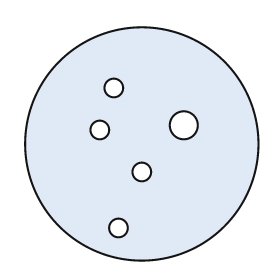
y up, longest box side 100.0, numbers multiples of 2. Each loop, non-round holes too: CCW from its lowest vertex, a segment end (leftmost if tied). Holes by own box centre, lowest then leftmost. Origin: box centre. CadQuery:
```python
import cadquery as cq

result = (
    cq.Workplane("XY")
    .moveTo(0.0, 0.0)
    .circle(50.0)
    .moveTo(-10.0, -36.0)
    .circle(4.0)
    .moveTo(0.0, -12.0)
    .circle(4.0)
    .moveTo(-18.0, 6.0)
    .circle(4.0)
    .moveTo(18.0, 8.0)
    .circle(6.0)
    .moveTo(-12.0, 24.0)
    .circle(4.0)
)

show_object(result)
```